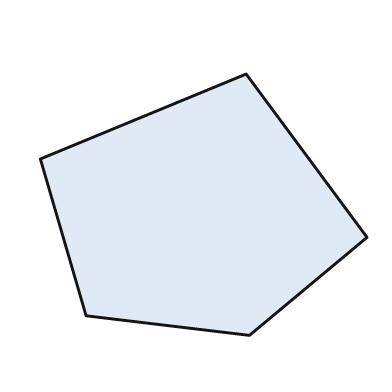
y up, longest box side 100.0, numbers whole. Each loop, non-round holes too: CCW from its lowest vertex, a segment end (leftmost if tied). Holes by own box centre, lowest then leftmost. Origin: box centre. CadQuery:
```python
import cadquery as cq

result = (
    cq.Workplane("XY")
    .moveTo(14.0, -40.0)
    .lineTo(50.0, -10.0)
    .lineTo(13.0, 40.0)
    .lineTo(-50.0, 14.0)
    .lineTo(-36.0, -34.0)
    .close()
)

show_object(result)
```